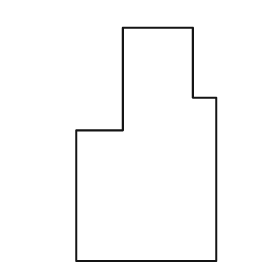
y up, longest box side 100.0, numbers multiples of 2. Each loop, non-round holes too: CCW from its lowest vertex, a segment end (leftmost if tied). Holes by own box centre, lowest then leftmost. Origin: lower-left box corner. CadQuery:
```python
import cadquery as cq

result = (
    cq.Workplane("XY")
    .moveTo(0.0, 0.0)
    .lineTo(60.0, 0.0)
    .lineTo(60.0, 70.0)
    .lineTo(50.0, 70.0)
    .lineTo(50.0, 100.0)
    .lineTo(20.0, 100.0)
    .lineTo(20.0, 56.0)
    .lineTo(0.0, 56.0)
    .close()
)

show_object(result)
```